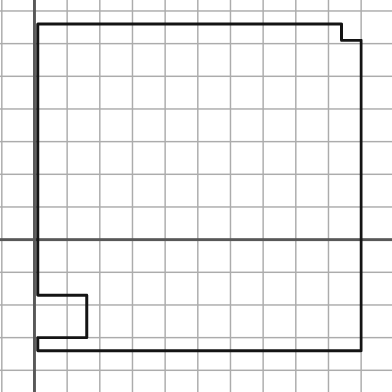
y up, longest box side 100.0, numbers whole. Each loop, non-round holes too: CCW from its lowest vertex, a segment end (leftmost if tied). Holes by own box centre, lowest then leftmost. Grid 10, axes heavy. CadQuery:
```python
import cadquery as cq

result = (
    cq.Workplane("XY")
    .moveTo(1.0, -34.0)
    .lineTo(100.0, -34.0)
    .lineTo(100.0, 61.0)
    .lineTo(94.0, 61.0)
    .lineTo(94.0, 66.0)
    .lineTo(1.0, 66.0)
    .lineTo(1.0, -17.0)
    .lineTo(16.0, -17.0)
    .lineTo(16.0, -30.0)
    .lineTo(1.0, -30.0)
    .close()
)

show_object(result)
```